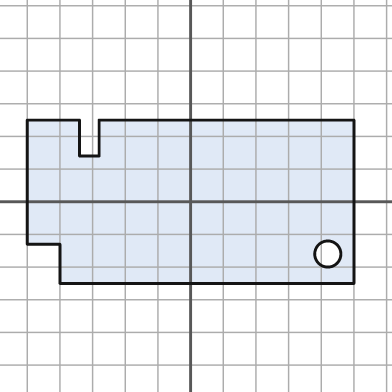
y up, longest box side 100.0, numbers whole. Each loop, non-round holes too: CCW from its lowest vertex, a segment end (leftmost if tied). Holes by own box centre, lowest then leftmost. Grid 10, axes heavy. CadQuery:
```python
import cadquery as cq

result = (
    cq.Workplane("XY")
    .moveTo(-40.0, -25.0)
    .lineTo(50.0, -25.0)
    .lineTo(50.0, 25.0)
    .lineTo(-28.0, 25.0)
    .lineTo(-28.0, 14.0)
    .lineTo(-34.0, 14.0)
    .lineTo(-34.0, 25.0)
    .lineTo(-50.0, 25.0)
    .lineTo(-50.0, -13.0)
    .lineTo(-40.0, -13.0)
    .close()
    .moveTo(42.0, -16.0)
    .circle(4.0)
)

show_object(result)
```